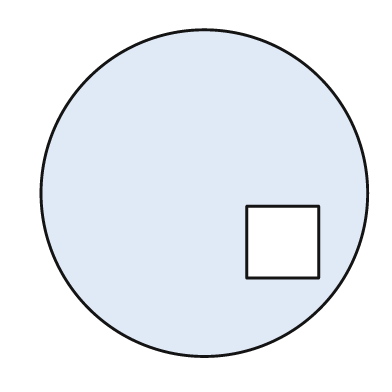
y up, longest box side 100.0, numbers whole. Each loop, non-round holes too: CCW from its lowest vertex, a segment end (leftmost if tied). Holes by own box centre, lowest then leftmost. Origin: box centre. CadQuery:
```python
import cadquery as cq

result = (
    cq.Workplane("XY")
    .moveTo(0.0, 0.0)
    .circle(50.0)
    .moveTo(13.0, -26.0)
    .lineTo(35.0, -26.0)
    .lineTo(35.0, -4.0)
    .lineTo(13.0, -4.0)
    .close()
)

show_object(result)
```